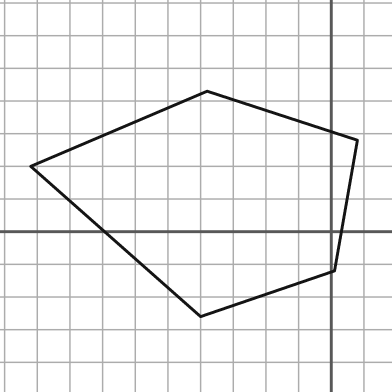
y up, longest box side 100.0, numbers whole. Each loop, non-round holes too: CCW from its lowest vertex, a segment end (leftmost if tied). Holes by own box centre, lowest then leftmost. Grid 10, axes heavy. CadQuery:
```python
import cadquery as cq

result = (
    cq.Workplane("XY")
    .moveTo(-40.0, -26.0)
    .lineTo(1.0, -12.0)
    .lineTo(8.0, 28.0)
    .lineTo(-38.0, 43.0)
    .lineTo(-92.0, 20.0)
    .close()
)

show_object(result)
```